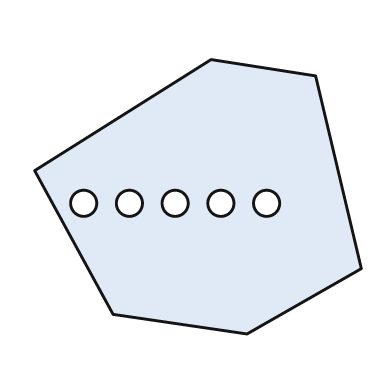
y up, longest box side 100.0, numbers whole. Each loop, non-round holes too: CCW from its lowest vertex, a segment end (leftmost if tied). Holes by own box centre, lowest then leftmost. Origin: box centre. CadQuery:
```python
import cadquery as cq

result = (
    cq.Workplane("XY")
    .moveTo(15.0, -42.0)
    .lineTo(50.0, -22.0)
    .lineTo(36.0, 37.0)
    .lineTo(4.0, 42.0)
    .lineTo(-50.0, 8.0)
    .lineTo(-26.0, -36.0)
    .close()
    .moveTo(-35.0, -2.0)
    .circle(4.0)
    .moveTo(-21.0, -2.0)
    .circle(4.0)
    .moveTo(-7.0, -2.0)
    .circle(4.0)
    .moveTo(7.0, -2.0)
    .circle(4.0)
    .moveTo(21.0, -2.0)
    .circle(4.0)
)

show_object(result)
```